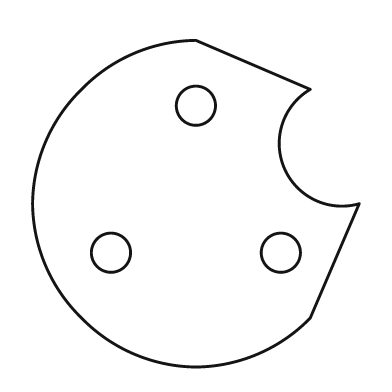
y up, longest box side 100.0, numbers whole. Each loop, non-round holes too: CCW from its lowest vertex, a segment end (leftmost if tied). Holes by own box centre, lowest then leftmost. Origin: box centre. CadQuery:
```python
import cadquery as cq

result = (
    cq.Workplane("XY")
    .moveTo(0.0, -50.0)
    .threePointArc((19.0, -46.0), (35.0, -35.0))
    .lineTo(50.0, 0.0)
    .threePointArc((27.0, 11.0), (35.0, 35.0))
    .lineTo(0.0, 50.0)
    .threePointArc((-19.0, 46.0), (-35.0, 35.0))
    .threePointArc((-46.0, 19.0), (-50.0, 0.0))
    .threePointArc((-46.0, -19.0), (-35.0, -35.0))
    .threePointArc((-19.0, -46.0), (0.0, -50.0))
    .close()
    .moveTo(-26.0, -15.0)
    .circle(6.0)
    .moveTo(26.0, -15.0)
    .circle(6.0)
    .moveTo(0.0, 30.0)
    .circle(6.0)
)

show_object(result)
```